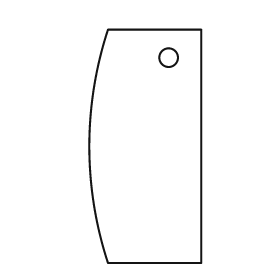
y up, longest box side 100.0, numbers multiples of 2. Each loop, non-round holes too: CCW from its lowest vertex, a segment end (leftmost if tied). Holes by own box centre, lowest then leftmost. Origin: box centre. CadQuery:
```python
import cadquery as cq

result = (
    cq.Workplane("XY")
    .moveTo(-16.0, -50.0)
    .lineTo(24.0, -50.0)
    .lineTo(24.0, 50.0)
    .lineTo(-16.0, 50.0)
    .threePointArc((-24.0, 0.0), (-16.0, -50.0))
    .close()
    .moveTo(10.0, 38.0)
    .circle(4.0)
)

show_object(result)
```